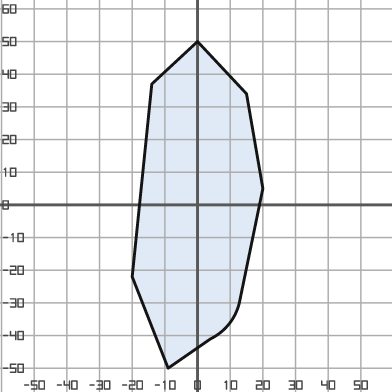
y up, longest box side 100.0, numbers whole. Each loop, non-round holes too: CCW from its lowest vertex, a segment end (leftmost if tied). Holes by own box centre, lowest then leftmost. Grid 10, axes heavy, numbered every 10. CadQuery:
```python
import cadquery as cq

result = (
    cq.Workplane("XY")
    .moveTo(-9.0, -50.0)
    .lineTo(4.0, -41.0)
    .threePointArc((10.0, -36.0), (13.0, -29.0))
    .lineTo(20.0, 5.0)
    .lineTo(15.0, 34.0)
    .lineTo(0.0, 50.0)
    .lineTo(-14.0, 37.0)
    .lineTo(-20.0, -22.0)
    .close()
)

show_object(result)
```